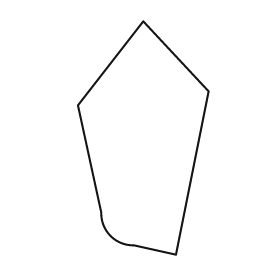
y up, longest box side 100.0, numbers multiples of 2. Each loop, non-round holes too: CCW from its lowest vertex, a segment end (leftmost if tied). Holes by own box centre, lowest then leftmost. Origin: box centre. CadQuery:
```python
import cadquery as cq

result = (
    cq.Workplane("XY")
    .moveTo(14.0, -50.0)
    .lineTo(28.0, 20.0)
    .lineTo(0.0, 50.0)
    .lineTo(-28.0, 14.0)
    .lineTo(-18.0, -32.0)
    .threePointArc((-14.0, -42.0), (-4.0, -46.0))
    .close()
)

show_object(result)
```